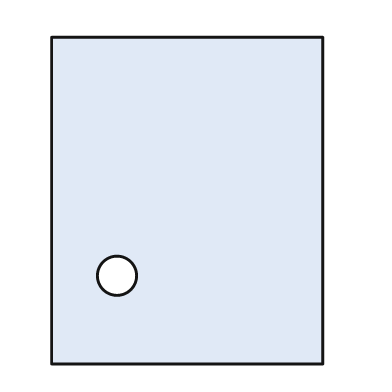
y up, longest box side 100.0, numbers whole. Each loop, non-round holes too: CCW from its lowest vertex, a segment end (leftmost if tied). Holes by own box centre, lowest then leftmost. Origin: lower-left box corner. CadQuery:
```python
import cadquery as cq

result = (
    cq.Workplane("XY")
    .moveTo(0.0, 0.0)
    .lineTo(83.0, 0.0)
    .lineTo(83.0, 100.0)
    .lineTo(0.0, 100.0)
    .close()
    .moveTo(20.0, 27.0)
    .circle(6.0)
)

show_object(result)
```